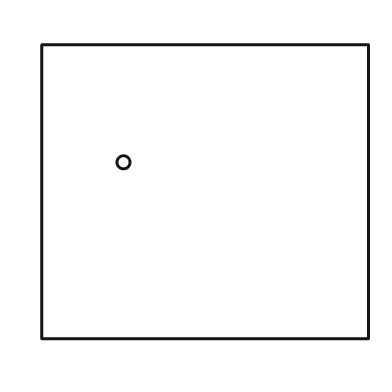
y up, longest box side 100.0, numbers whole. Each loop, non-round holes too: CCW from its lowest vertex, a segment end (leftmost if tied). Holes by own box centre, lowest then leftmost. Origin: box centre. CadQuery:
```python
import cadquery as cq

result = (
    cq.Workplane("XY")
    .moveTo(-50.0, -45.0)
    .lineTo(50.0, -45.0)
    .lineTo(50.0, 45.0)
    .lineTo(-50.0, 45.0)
    .close()
    .moveTo(-25.0, 9.0)
    .circle(2.0)
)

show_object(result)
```